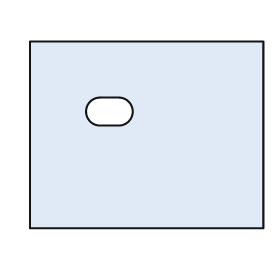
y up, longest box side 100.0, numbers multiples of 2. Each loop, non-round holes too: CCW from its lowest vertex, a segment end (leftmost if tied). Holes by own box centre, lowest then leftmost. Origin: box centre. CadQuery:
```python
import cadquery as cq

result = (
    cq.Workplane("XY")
    .moveTo(-50.0, -40.0)
    .lineTo(50.0, -40.0)
    .lineTo(50.0, 40.0)
    .lineTo(-50.0, 40.0)
    .close()
    .moveTo(-20.0, 4.0)
    .lineTo(-12.0, 4.0)
    .threePointArc((-6.0, 10.0), (-12.0, 16.0))
    .lineTo(-20.0, 16.0)
    .threePointArc((-26.0, 10.0), (-20.0, 4.0))
    .close()
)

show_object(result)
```